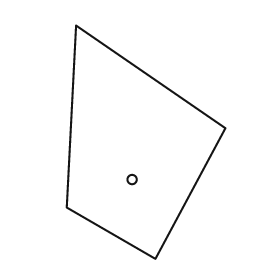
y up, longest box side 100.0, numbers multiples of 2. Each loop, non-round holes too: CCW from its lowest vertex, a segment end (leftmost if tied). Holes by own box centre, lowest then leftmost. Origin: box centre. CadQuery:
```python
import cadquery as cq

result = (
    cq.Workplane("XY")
    .moveTo(4.0, -50.0)
    .lineTo(34.0, 6.0)
    .lineTo(-30.0, 50.0)
    .lineTo(-34.0, -28.0)
    .close()
    .moveTo(-6.0, -16.0)
    .circle(2.0)
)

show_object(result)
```